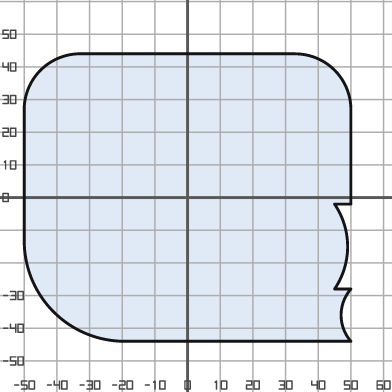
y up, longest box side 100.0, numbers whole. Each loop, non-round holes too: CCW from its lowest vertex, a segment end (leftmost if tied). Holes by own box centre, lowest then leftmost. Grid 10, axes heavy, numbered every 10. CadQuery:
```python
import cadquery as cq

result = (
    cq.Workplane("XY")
    .moveTo(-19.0, -44.0)
    .lineTo(50.0, -44.0)
    .threePointArc((47.0, -36.0), (50.0, -28.0))
    .lineTo(45.0, -28.0)
    .threePointArc((49.0, -15.0), (45.0, -2.0))
    .lineTo(50.0, -2.0)
    .lineTo(50.0, 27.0)
    .threePointArc((45.0, 39.0), (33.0, 44.0))
    .lineTo(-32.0, 44.0)
    .threePointArc((-45.0, 39.0), (-50.0, 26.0))
    .lineTo(-50.0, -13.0)
    .threePointArc((-41.0, -35.0), (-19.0, -44.0))
    .close()
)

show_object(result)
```